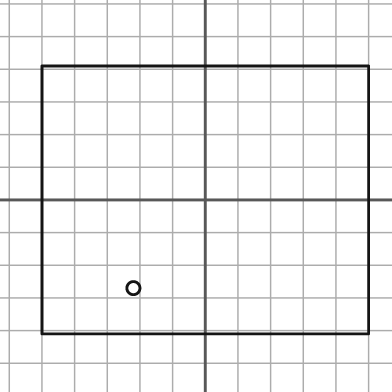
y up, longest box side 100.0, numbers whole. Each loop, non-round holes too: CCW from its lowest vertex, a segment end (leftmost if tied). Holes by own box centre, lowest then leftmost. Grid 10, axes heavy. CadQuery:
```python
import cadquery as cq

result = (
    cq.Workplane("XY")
    .moveTo(-50.0, -41.0)
    .lineTo(50.0, -41.0)
    .lineTo(50.0, 41.0)
    .lineTo(-50.0, 41.0)
    .close()
    .moveTo(-22.0, -27.0)
    .circle(2.0)
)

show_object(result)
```